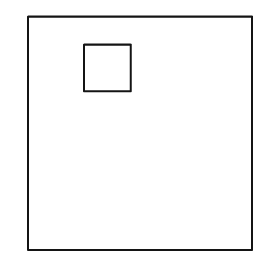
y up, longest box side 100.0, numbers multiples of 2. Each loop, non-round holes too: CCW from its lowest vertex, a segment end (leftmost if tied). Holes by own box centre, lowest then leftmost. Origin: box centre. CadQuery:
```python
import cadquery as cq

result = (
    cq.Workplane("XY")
    .moveTo(-48.0, -50.0)
    .lineTo(48.0, -50.0)
    .lineTo(48.0, 50.0)
    .lineTo(-48.0, 50.0)
    .close()
    .moveTo(-24.0, 18.0)
    .lineTo(-4.0, 18.0)
    .lineTo(-4.0, 38.0)
    .lineTo(-24.0, 38.0)
    .close()
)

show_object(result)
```